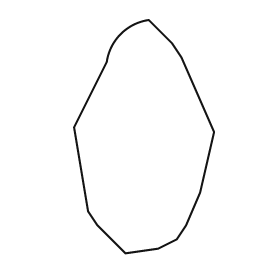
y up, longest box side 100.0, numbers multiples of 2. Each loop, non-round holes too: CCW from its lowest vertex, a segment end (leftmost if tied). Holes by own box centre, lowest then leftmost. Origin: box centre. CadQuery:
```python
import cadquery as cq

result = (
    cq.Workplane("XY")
    .moveTo(-8.0, -50.0)
    .lineTo(6.0, -48.0)
    .lineTo(14.0, -44.0)
    .lineTo(18.0, -38.0)
    .lineTo(24.0, -24.0)
    .lineTo(30.0, 2.0)
    .lineTo(16.0, 34.0)
    .lineTo(12.0, 40.0)
    .lineTo(2.0, 50.0)
    .threePointArc((-10.0, 44.0), (-16.0, 32.0))
    .lineTo(-30.0, 4.0)
    .lineTo(-24.0, -32.0)
    .lineTo(-20.0, -38.0)
    .close()
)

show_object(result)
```